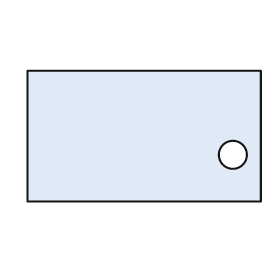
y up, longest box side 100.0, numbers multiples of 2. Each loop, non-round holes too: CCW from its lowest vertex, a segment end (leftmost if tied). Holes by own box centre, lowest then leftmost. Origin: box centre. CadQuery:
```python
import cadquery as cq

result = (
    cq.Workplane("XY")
    .moveTo(-50.0, -28.0)
    .lineTo(50.0, -28.0)
    .lineTo(50.0, 28.0)
    .lineTo(-50.0, 28.0)
    .close()
    .moveTo(38.0, -8.0)
    .circle(6.0)
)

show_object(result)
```